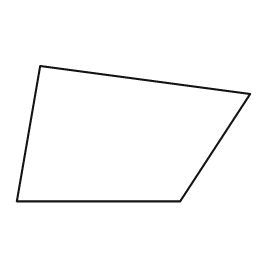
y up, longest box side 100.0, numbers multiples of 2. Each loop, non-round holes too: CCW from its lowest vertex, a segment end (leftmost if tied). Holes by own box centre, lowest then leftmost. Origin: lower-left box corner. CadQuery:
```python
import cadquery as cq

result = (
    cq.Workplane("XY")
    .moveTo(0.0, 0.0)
    .lineTo(70.0, 0.0)
    .lineTo(100.0, 46.0)
    .lineTo(10.0, 58.0)
    .close()
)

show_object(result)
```